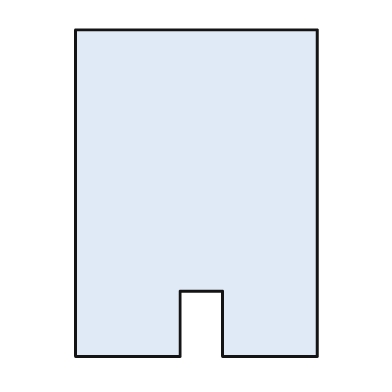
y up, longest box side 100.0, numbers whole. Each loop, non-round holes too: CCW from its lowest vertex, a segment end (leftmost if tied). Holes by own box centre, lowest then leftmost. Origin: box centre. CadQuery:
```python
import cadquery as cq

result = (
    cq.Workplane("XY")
    .moveTo(-37.0, -50.0)
    .lineTo(-5.0, -50.0)
    .lineTo(-5.0, -30.0)
    .lineTo(8.0, -30.0)
    .lineTo(8.0, -50.0)
    .lineTo(37.0, -50.0)
    .lineTo(37.0, 50.0)
    .lineTo(-37.0, 50.0)
    .close()
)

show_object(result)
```